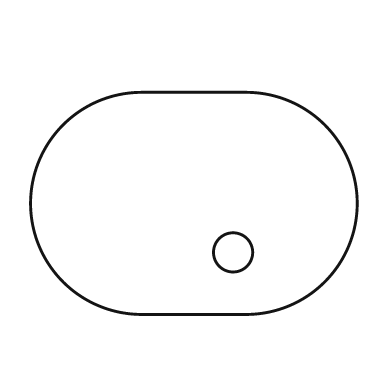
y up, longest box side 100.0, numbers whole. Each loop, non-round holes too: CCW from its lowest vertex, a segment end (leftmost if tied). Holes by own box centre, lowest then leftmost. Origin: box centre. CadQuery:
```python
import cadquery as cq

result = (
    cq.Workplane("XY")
    .moveTo(-16.0, -34.0)
    .lineTo(16.0, -34.0)
    .threePointArc((50.0, 0.0), (16.0, 34.0))
    .lineTo(-16.0, 34.0)
    .threePointArc((-50.0, 0.0), (-16.0, -34.0))
    .close()
    .moveTo(12.0, -15.0)
    .circle(6.0)
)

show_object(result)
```